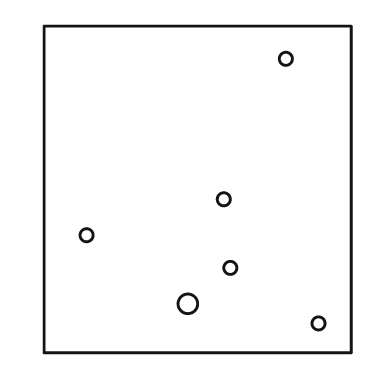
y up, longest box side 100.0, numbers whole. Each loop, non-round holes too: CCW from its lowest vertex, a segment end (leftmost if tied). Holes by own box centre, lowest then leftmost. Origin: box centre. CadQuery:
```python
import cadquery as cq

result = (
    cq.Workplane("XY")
    .moveTo(-47.0, -50.0)
    .lineTo(47.0, -50.0)
    .lineTo(47.0, 50.0)
    .lineTo(-47.0, 50.0)
    .close()
    .moveTo(37.0, -41.0)
    .circle(2.0)
    .moveTo(-3.0, -35.0)
    .circle(3.0)
    .moveTo(10.0, -24.0)
    .circle(2.0)
    .moveTo(-34.0, -14.0)
    .circle(2.0)
    .moveTo(8.0, -3.0)
    .circle(2.0)
    .moveTo(27.0, 40.0)
    .circle(2.0)
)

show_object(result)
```